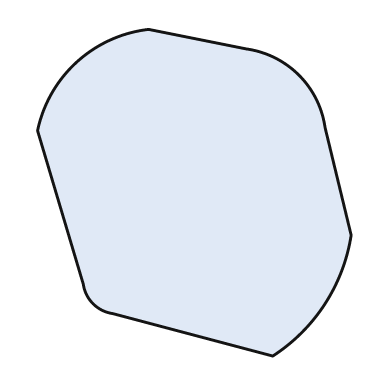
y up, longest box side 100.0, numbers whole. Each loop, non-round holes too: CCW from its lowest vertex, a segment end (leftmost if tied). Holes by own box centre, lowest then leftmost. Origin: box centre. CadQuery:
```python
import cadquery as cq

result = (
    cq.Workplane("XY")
    .moveTo(24.0, -50.0)
    .threePointArc((40.0, -34.0), (48.0, -13.0))
    .lineTo(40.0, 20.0)
    .threePointArc((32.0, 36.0), (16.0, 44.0))
    .lineTo(-14.0, 50.0)
    .threePointArc((-36.0, 40.0), (-48.0, 19.0))
    .lineTo(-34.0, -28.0)
    .threePointArc((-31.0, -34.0), (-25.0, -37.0))
    .close()
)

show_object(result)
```